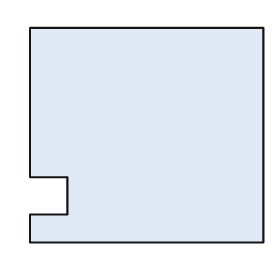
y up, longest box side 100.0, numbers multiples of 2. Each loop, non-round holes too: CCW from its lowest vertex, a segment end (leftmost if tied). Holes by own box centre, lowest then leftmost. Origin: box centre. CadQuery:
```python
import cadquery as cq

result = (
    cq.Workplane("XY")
    .moveTo(-50.0, -46.0)
    .lineTo(50.0, -46.0)
    .lineTo(50.0, 46.0)
    .lineTo(-50.0, 46.0)
    .lineTo(-50.0, -18.0)
    .lineTo(-34.0, -18.0)
    .lineTo(-34.0, -34.0)
    .lineTo(-50.0, -34.0)
    .close()
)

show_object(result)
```